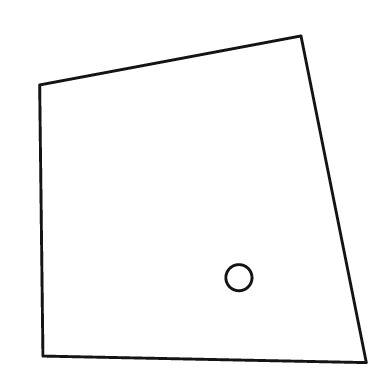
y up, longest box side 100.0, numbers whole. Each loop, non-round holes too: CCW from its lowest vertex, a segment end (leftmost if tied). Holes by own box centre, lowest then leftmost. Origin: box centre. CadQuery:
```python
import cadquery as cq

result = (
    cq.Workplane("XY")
    .moveTo(50.0, -50.0)
    .lineTo(30.0, 50.0)
    .lineTo(-50.0, 35.0)
    .lineTo(-49.0, -48.0)
    .close()
    .moveTo(11.0, -24.0)
    .circle(4.0)
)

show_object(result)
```